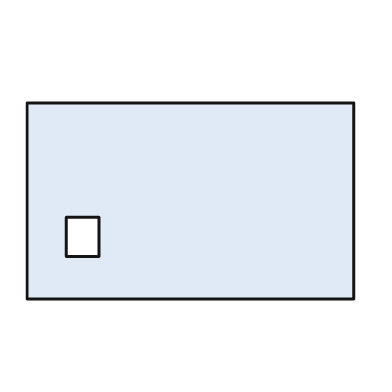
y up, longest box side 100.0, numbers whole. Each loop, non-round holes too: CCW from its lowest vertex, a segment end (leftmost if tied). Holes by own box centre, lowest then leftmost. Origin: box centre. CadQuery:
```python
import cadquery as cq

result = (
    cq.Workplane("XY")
    .moveTo(-50.0, -30.0)
    .lineTo(50.0, -30.0)
    .lineTo(50.0, 30.0)
    .lineTo(-50.0, 30.0)
    .close()
    .moveTo(-38.0, -17.0)
    .lineTo(-28.0, -17.0)
    .lineTo(-28.0, -5.0)
    .lineTo(-38.0, -5.0)
    .close()
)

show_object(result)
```